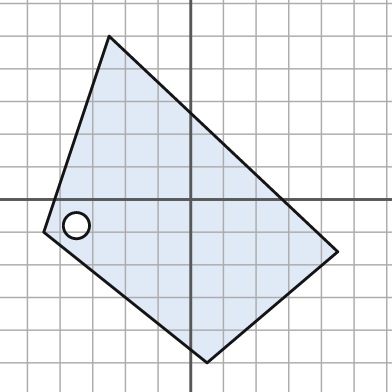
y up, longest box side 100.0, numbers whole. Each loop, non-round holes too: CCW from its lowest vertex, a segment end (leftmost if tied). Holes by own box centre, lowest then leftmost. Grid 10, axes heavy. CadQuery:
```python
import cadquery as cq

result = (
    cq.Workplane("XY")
    .moveTo(5.0, -50.0)
    .lineTo(45.0, -16.0)
    .lineTo(-25.0, 50.0)
    .lineTo(-45.0, -10.0)
    .close()
    .moveTo(-35.0, -8.0)
    .circle(4.0)
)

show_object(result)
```